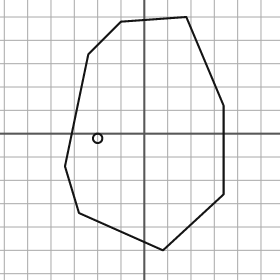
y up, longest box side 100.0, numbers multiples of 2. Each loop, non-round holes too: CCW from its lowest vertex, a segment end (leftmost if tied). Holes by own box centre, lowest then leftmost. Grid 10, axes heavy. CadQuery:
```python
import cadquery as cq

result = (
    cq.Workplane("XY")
    .moveTo(8.0, -50.0)
    .lineTo(34.0, -26.0)
    .lineTo(34.0, 12.0)
    .lineTo(18.0, 50.0)
    .lineTo(-10.0, 48.0)
    .lineTo(-24.0, 34.0)
    .lineTo(-34.0, -14.0)
    .lineTo(-28.0, -34.0)
    .close()
    .moveTo(-20.0, -2.0)
    .circle(2.0)
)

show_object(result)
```